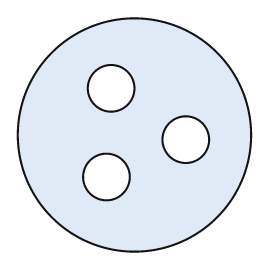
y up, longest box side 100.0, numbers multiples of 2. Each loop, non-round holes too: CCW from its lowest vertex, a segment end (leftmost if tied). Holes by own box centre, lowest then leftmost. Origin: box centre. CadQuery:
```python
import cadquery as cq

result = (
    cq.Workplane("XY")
    .moveTo(0.0, 0.0)
    .circle(50.0)
    .moveTo(-12.0, -18.0)
    .circle(10.0)
    .moveTo(22.0, -2.0)
    .circle(10.0)
    .moveTo(-10.0, 20.0)
    .circle(10.0)
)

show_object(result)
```